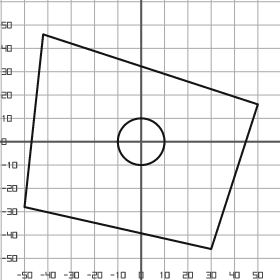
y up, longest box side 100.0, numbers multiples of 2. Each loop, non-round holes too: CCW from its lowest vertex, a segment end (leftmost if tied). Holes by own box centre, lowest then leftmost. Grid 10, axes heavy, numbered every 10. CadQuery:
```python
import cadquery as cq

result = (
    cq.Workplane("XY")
    .moveTo(30.0, -46.0)
    .lineTo(50.0, 16.0)
    .lineTo(-42.0, 46.0)
    .lineTo(-50.0, -28.0)
    .close()
    .moveTo(0.0, 0.0)
    .circle(10.0)
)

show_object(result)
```